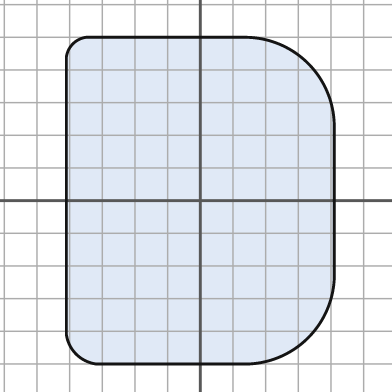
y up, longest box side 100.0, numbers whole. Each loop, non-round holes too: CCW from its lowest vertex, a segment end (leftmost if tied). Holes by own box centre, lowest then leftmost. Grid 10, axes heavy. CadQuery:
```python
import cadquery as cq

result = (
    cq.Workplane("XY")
    .moveTo(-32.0, -50.0)
    .lineTo(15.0, -50.0)
    .threePointArc((33.0, -42.0), (41.0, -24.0))
    .lineTo(41.0, 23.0)
    .threePointArc((33.0, 42.0), (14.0, 50.0))
    .lineTo(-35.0, 50.0)
    .threePointArc((-39.0, 48.0), (-41.0, 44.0))
    .lineTo(-41.0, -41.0)
    .threePointArc((-38.0, -47.0), (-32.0, -50.0))
    .close()
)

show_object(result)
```